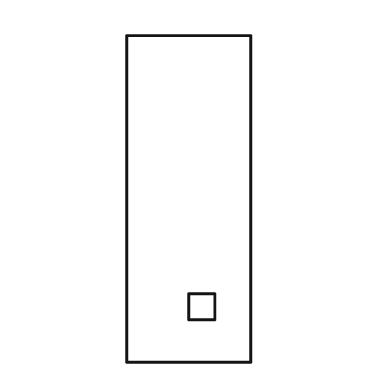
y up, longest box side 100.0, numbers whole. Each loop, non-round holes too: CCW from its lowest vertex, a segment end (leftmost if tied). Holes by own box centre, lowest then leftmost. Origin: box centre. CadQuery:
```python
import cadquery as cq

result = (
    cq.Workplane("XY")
    .moveTo(-19.0, -50.0)
    .lineTo(19.0, -50.0)
    .lineTo(19.0, 50.0)
    .lineTo(-19.0, 50.0)
    .close()
    .moveTo(0.0, -37.0)
    .lineTo(8.0, -37.0)
    .lineTo(8.0, -29.0)
    .lineTo(0.0, -29.0)
    .close()
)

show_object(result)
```